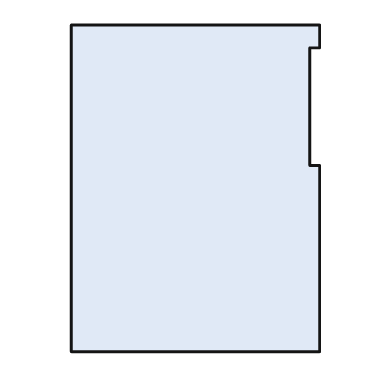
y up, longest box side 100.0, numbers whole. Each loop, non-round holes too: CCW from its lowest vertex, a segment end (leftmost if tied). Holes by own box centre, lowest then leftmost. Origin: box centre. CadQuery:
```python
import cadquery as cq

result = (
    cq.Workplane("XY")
    .moveTo(-38.0, -50.0)
    .lineTo(38.0, -50.0)
    .lineTo(38.0, 7.0)
    .lineTo(35.0, 7.0)
    .lineTo(35.0, 43.0)
    .lineTo(38.0, 43.0)
    .lineTo(38.0, 50.0)
    .lineTo(-38.0, 50.0)
    .close()
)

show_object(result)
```